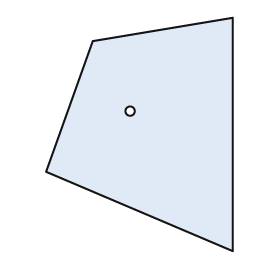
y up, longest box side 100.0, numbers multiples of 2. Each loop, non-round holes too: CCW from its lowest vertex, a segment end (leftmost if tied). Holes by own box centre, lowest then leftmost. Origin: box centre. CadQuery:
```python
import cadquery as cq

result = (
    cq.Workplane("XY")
    .moveTo(40.0, -50.0)
    .lineTo(40.0, 50.0)
    .lineTo(-20.0, 40.0)
    .lineTo(-40.0, -16.0)
    .close()
    .moveTo(-4.0, 10.0)
    .circle(2.0)
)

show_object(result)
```